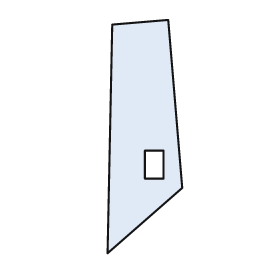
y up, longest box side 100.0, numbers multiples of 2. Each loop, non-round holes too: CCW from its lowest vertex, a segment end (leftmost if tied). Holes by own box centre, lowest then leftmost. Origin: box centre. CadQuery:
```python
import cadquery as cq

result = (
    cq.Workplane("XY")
    .moveTo(-16.0, -50.0)
    .lineTo(16.0, -22.0)
    .lineTo(10.0, 50.0)
    .lineTo(-14.0, 48.0)
    .close()
    .moveTo(0.0, -18.0)
    .lineTo(8.0, -18.0)
    .lineTo(8.0, -6.0)
    .lineTo(0.0, -6.0)
    .close()
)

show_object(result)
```